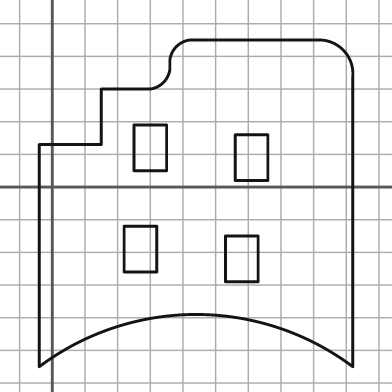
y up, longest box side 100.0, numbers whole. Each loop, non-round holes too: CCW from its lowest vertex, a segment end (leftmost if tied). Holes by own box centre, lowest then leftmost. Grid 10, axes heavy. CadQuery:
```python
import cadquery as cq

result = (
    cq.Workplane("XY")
    .moveTo(-4.0, -55.0)
    .threePointArc((44.0, -39.0), (92.0, -55.0))
    .lineTo(92.0, 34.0)
    .threePointArc((89.0, 42.0), (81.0, 45.0))
    .lineTo(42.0, 45.0)
    .threePointArc((38.0, 43.0), (36.0, 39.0))
    .lineTo(36.0, 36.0)
    .threePointArc((34.0, 32.0), (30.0, 30.0))
    .lineTo(15.0, 30.0)
    .lineTo(15.0, 13.0)
    .lineTo(-4.0, 13.0)
    .close()
    .moveTo(53.0, -29.0)
    .lineTo(63.0, -29.0)
    .lineTo(63.0, -15.0)
    .lineTo(53.0, -15.0)
    .close()
    .moveTo(22.0, -26.0)
    .lineTo(32.0, -26.0)
    .lineTo(32.0, -12.0)
    .lineTo(22.0, -12.0)
    .close()
    .moveTo(56.0, 2.0)
    .lineTo(66.0, 2.0)
    .lineTo(66.0, 16.0)
    .lineTo(56.0, 16.0)
    .close()
    .moveTo(25.0, 5.0)
    .lineTo(35.0, 5.0)
    .lineTo(35.0, 19.0)
    .lineTo(25.0, 19.0)
    .close()
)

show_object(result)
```